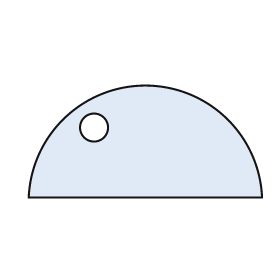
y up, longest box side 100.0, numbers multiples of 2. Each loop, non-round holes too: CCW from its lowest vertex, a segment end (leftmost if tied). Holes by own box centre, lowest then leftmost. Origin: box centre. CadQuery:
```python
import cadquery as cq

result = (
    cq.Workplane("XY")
    .moveTo(-50.0, -24.0)
    .lineTo(50.0, -24.0)
    .threePointArc((0.0, 24.0), (-50.0, -24.0))
    .close()
    .moveTo(-22.0, 6.0)
    .circle(6.0)
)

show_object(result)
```